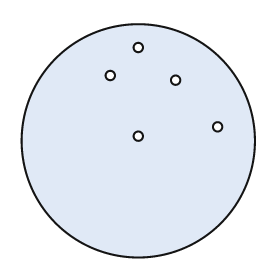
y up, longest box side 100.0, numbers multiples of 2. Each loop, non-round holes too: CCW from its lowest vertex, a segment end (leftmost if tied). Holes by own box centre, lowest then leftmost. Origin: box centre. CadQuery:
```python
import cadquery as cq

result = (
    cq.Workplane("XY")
    .moveTo(0.0, 0.0)
    .circle(50.0)
    .moveTo(0.0, 2.0)
    .circle(2.0)
    .moveTo(34.0, 6.0)
    .circle(2.0)
    .moveTo(16.0, 26.0)
    .circle(2.0)
    .moveTo(-12.0, 28.0)
    .circle(2.0)
    .moveTo(0.0, 40.0)
    .circle(2.0)
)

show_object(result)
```